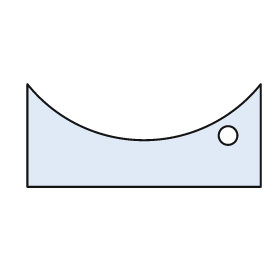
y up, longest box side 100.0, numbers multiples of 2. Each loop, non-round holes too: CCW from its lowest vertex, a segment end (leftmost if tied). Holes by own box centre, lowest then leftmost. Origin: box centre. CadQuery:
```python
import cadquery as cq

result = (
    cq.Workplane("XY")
    .moveTo(-50.0, -22.0)
    .lineTo(50.0, -22.0)
    .lineTo(50.0, 22.0)
    .threePointArc((0.0, -2.0), (-50.0, 22.0))
    .close()
    .moveTo(36.0, 0.0)
    .circle(4.0)
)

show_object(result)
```